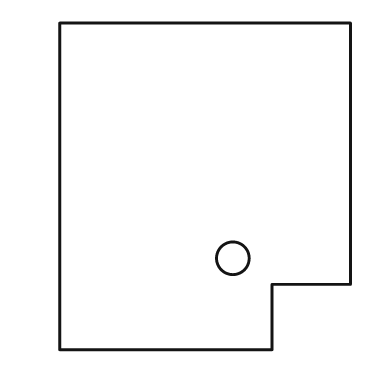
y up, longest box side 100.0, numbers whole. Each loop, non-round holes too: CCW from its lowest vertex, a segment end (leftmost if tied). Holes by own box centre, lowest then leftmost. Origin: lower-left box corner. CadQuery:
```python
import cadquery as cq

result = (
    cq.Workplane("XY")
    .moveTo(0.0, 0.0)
    .lineTo(65.0, 0.0)
    .lineTo(65.0, 20.0)
    .lineTo(89.0, 20.0)
    .lineTo(89.0, 100.0)
    .lineTo(0.0, 100.0)
    .close()
    .moveTo(53.0, 28.0)
    .circle(5.0)
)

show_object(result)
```